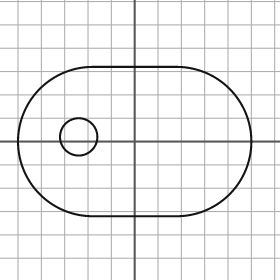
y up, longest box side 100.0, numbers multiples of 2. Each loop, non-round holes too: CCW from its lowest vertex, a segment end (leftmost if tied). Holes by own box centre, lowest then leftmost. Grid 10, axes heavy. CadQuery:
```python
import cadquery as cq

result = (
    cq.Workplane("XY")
    .moveTo(-18.0, -32.0)
    .lineTo(18.0, -32.0)
    .threePointArc((50.0, 0.0), (18.0, 32.0))
    .lineTo(-18.0, 32.0)
    .threePointArc((-50.0, 0.0), (-18.0, -32.0))
    .close()
    .moveTo(-24.0, 2.0)
    .circle(8.0)
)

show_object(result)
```